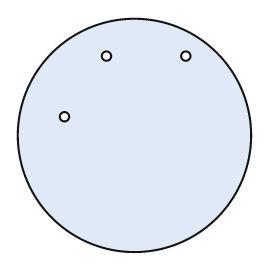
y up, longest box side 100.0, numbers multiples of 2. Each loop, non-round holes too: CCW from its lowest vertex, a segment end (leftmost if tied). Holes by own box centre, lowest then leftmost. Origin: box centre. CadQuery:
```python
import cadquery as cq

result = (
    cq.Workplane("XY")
    .moveTo(0.0, 0.0)
    .circle(50.0)
    .moveTo(-30.0, 8.0)
    .circle(2.0)
    .moveTo(-12.0, 34.0)
    .circle(2.0)
    .moveTo(22.0, 34.0)
    .circle(2.0)
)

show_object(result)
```